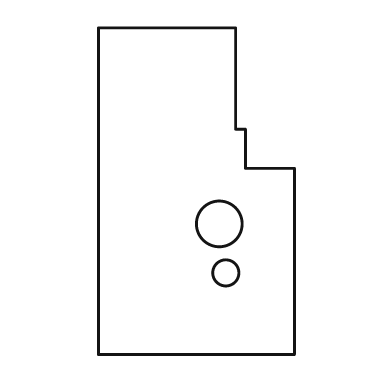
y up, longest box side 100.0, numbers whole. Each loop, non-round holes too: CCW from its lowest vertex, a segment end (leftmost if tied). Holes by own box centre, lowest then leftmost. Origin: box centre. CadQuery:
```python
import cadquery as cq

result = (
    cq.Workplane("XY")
    .moveTo(-30.0, -50.0)
    .lineTo(30.0, -50.0)
    .lineTo(30.0, 7.0)
    .lineTo(15.0, 7.0)
    .lineTo(15.0, 19.0)
    .lineTo(12.0, 19.0)
    .lineTo(12.0, 50.0)
    .lineTo(-30.0, 50.0)
    .close()
    .moveTo(9.0, -25.0)
    .circle(4.0)
    .moveTo(7.0, -10.0)
    .circle(7.0)
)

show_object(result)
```